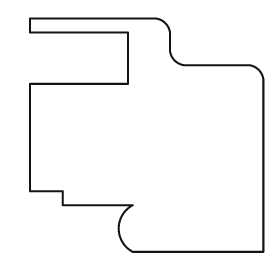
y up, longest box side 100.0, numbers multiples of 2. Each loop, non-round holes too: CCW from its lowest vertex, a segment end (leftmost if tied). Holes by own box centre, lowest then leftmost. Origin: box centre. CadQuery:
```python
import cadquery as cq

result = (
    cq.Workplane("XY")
    .moveTo(-6.0, -50.0)
    .lineTo(50.0, -50.0)
    .lineTo(50.0, 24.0)
    .threePointArc((48.0, 28.0), (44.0, 30.0))
    .lineTo(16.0, 30.0)
    .threePointArc((12.0, 32.0), (10.0, 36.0))
    .lineTo(10.0, 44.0)
    .threePointArc((8.0, 48.0), (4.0, 50.0))
    .lineTo(-50.0, 50.0)
    .lineTo(-50.0, 44.0)
    .lineTo(-8.0, 44.0)
    .lineTo(-8.0, 22.0)
    .lineTo(-50.0, 22.0)
    .lineTo(-50.0, -24.0)
    .lineTo(-36.0, -24.0)
    .lineTo(-36.0, -30.0)
    .lineTo(-6.0, -30.0)
    .threePointArc((-12.0, -40.0), (-6.0, -50.0))
    .close()
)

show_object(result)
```